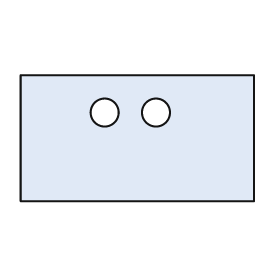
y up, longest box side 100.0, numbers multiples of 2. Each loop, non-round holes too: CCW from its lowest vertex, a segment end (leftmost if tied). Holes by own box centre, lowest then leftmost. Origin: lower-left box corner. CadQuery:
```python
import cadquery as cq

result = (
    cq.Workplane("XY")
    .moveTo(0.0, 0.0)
    .lineTo(100.0, 0.0)
    .lineTo(100.0, 54.0)
    .lineTo(0.0, 54.0)
    .close()
    .moveTo(36.0, 38.0)
    .circle(6.0)
    .moveTo(58.0, 38.0)
    .circle(6.0)
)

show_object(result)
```